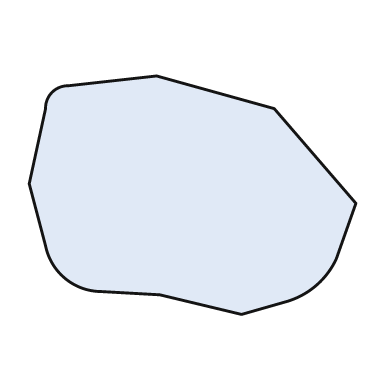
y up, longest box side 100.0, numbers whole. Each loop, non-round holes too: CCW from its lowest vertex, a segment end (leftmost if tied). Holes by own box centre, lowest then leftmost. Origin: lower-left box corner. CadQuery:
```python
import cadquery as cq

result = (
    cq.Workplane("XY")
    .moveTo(65.0, 0.0)
    .lineTo(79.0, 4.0)
    .threePointArc((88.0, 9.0), (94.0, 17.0))
    .lineTo(100.0, 34.0)
    .lineTo(75.0, 63.0)
    .lineTo(39.0, 73.0)
    .lineTo(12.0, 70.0)
    .threePointArc((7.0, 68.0), (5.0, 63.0))
    .lineTo(0.0, 40.0)
    .lineTo(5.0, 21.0)
    .threePointArc((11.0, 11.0), (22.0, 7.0))
    .lineTo(40.0, 6.0)
    .close()
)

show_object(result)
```